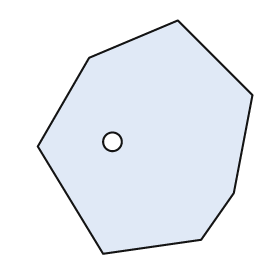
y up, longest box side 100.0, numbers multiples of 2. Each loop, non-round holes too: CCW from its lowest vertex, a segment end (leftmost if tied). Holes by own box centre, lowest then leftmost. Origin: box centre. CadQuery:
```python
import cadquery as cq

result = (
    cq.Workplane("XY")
    .moveTo(-18.0, -50.0)
    .lineTo(24.0, -44.0)
    .lineTo(38.0, -24.0)
    .lineTo(46.0, 18.0)
    .lineTo(14.0, 50.0)
    .lineTo(-24.0, 34.0)
    .lineTo(-46.0, -4.0)
    .close()
    .moveTo(-14.0, -2.0)
    .circle(4.0)
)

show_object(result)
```